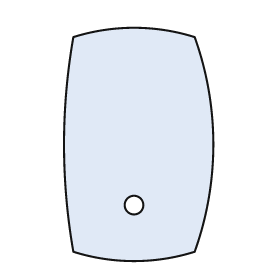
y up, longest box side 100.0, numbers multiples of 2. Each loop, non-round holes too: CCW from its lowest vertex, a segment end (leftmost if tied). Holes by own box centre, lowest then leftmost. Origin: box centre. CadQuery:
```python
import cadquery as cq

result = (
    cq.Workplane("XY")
    .moveTo(-28.0, -46.0)
    .threePointArc((-2.0, -50.0), (24.0, -46.0))
    .threePointArc((32.0, 0.0), (24.0, 46.0))
    .threePointArc((-2.0, 50.0), (-28.0, 46.0))
    .threePointArc((-32.0, 0.0), (-28.0, -46.0))
    .close()
    .moveTo(-2.0, -26.0)
    .circle(4.0)
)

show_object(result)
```